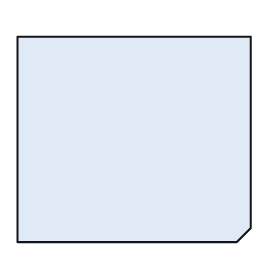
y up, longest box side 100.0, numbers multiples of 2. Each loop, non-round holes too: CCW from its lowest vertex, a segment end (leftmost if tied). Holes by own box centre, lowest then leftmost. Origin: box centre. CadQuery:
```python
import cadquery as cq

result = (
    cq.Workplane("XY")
    .moveTo(-50.0, -44.0)
    .lineTo(44.0, -44.0)
    .lineTo(50.0, -38.0)
    .lineTo(50.0, 44.0)
    .lineTo(-50.0, 44.0)
    .close()
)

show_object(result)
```